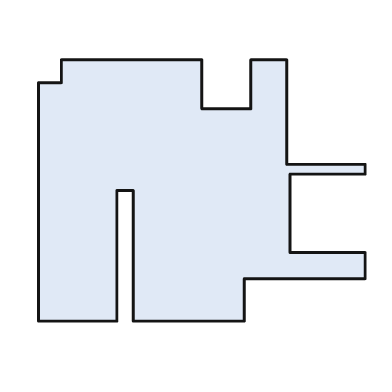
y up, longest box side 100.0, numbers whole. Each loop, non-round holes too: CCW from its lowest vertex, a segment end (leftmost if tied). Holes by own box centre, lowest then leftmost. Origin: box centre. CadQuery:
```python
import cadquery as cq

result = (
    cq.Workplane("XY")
    .moveTo(-50.0, -40.0)
    .lineTo(-26.0, -40.0)
    .lineTo(-26.0, 0.0)
    .lineTo(-21.0, 0.0)
    .lineTo(-21.0, -40.0)
    .lineTo(13.0, -40.0)
    .lineTo(13.0, -27.0)
    .lineTo(50.0, -27.0)
    .lineTo(50.0, -19.0)
    .lineTo(27.0, -19.0)
    .lineTo(27.0, 5.0)
    .lineTo(50.0, 5.0)
    .lineTo(50.0, 8.0)
    .lineTo(26.0, 8.0)
    .lineTo(26.0, 40.0)
    .lineTo(15.0, 40.0)
    .lineTo(15.0, 25.0)
    .lineTo(0.0, 25.0)
    .lineTo(0.0, 40.0)
    .lineTo(-43.0, 40.0)
    .lineTo(-43.0, 33.0)
    .lineTo(-50.0, 33.0)
    .close()
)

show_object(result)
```